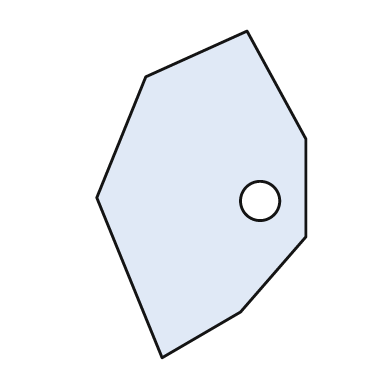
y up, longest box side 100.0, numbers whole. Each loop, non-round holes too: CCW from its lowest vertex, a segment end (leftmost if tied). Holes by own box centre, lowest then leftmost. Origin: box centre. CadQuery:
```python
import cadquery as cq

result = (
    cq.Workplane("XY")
    .moveTo(-12.0, -50.0)
    .lineTo(12.0, -36.0)
    .lineTo(32.0, -13.0)
    .lineTo(32.0, 17.0)
    .lineTo(14.0, 50.0)
    .lineTo(-17.0, 36.0)
    .lineTo(-32.0, -1.0)
    .close()
    .moveTo(18.0, -2.0)
    .circle(6.0)
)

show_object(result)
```